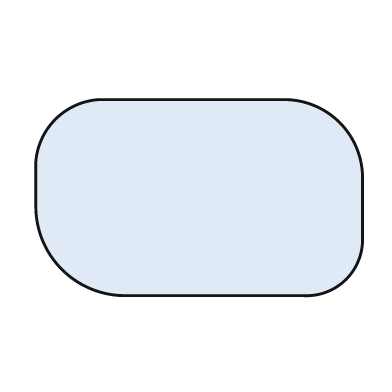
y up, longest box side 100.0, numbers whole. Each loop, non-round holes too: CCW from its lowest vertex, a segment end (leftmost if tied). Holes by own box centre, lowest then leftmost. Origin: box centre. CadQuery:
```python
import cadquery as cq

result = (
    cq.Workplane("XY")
    .moveTo(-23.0, -30.0)
    .lineTo(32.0, -30.0)
    .threePointArc((45.0, -25.0), (50.0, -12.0))
    .lineTo(50.0, 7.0)
    .threePointArc((43.0, 23.0), (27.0, 30.0))
    .lineTo(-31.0, 30.0)
    .threePointArc((-44.0, 24.0), (-50.0, 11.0))
    .lineTo(-50.0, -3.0)
    .threePointArc((-42.0, -22.0), (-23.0, -30.0))
    .close()
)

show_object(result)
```